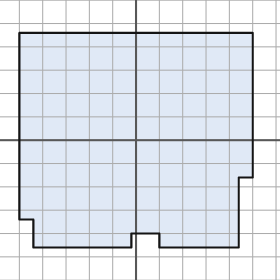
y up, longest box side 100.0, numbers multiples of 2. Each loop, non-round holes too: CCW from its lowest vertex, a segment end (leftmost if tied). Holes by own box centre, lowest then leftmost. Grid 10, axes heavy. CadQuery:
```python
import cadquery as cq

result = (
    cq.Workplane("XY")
    .moveTo(-44.0, -46.0)
    .lineTo(-2.0, -46.0)
    .lineTo(-2.0, -40.0)
    .lineTo(10.0, -40.0)
    .lineTo(10.0, -46.0)
    .lineTo(44.0, -46.0)
    .lineTo(44.0, -16.0)
    .lineTo(50.0, -16.0)
    .lineTo(50.0, 46.0)
    .lineTo(-50.0, 46.0)
    .lineTo(-50.0, -34.0)
    .lineTo(-44.0, -34.0)
    .close()
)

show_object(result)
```